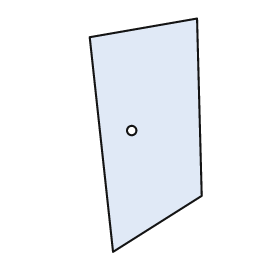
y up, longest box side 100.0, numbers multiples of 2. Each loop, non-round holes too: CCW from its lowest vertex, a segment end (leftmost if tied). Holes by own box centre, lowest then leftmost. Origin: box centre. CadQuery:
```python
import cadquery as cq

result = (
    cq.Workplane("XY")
    .moveTo(-14.0, -50.0)
    .lineTo(24.0, -26.0)
    .lineTo(22.0, 50.0)
    .lineTo(-24.0, 42.0)
    .close()
    .moveTo(-6.0, 2.0)
    .circle(2.0)
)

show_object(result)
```